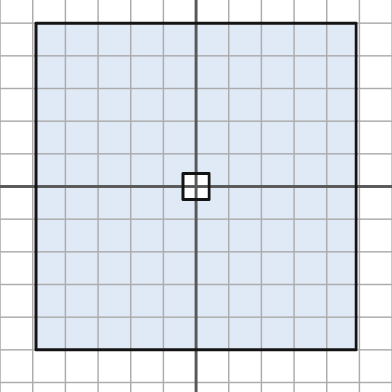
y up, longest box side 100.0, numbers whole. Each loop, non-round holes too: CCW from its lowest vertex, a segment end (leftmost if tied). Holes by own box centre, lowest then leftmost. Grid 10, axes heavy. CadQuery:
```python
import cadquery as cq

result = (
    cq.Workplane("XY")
    .moveTo(-49.0, -50.0)
    .lineTo(49.0, -50.0)
    .lineTo(49.0, 50.0)
    .lineTo(-49.0, 50.0)
    .close()
    .moveTo(-4.0, -4.0)
    .lineTo(4.0, -4.0)
    .lineTo(4.0, 4.0)
    .lineTo(-4.0, 4.0)
    .close()
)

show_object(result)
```